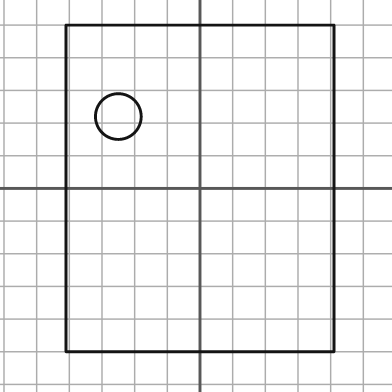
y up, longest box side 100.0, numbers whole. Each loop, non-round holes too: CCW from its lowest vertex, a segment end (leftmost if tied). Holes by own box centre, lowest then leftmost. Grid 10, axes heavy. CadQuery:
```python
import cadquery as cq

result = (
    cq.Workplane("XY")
    .moveTo(-41.0, -50.0)
    .lineTo(41.0, -50.0)
    .lineTo(41.0, 50.0)
    .lineTo(-41.0, 50.0)
    .close()
    .moveTo(-25.0, 22.0)
    .circle(7.0)
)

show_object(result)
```